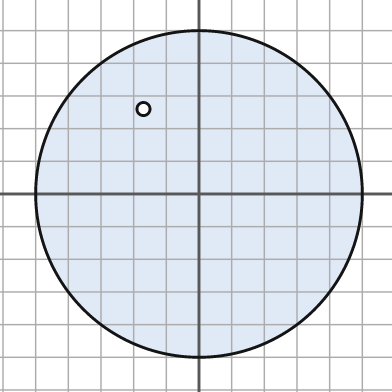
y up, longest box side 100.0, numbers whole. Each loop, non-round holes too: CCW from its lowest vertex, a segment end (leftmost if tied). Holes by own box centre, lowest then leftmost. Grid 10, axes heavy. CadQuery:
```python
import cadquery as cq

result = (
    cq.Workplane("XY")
    .moveTo(0.0, 0.0)
    .circle(50.0)
    .moveTo(-17.0, 26.0)
    .circle(2.0)
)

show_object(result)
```